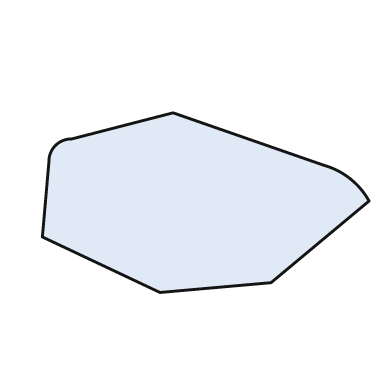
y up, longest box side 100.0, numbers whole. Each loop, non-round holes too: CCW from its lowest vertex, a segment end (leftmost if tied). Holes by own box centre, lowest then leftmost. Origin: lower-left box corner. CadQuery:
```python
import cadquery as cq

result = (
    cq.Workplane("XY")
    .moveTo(36.0, 0.0)
    .lineTo(70.0, 3.0)
    .lineTo(100.0, 28.0)
    .threePointArc((94.0, 35.0), (86.0, 39.0))
    .lineTo(40.0, 55.0)
    .lineTo(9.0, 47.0)
    .threePointArc((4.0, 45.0), (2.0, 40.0))
    .lineTo(0.0, 17.0)
    .close()
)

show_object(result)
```